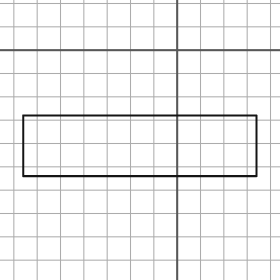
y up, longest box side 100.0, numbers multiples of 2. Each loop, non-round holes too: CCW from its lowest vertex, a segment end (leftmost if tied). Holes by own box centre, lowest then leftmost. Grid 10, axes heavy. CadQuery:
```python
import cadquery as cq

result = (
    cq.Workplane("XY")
    .moveTo(-66.0, -54.0)
    .lineTo(34.0, -54.0)
    .lineTo(34.0, -28.0)
    .lineTo(-66.0, -28.0)
    .close()
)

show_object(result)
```